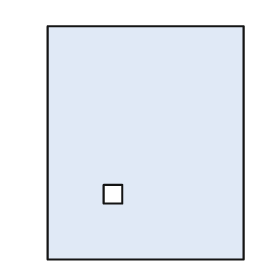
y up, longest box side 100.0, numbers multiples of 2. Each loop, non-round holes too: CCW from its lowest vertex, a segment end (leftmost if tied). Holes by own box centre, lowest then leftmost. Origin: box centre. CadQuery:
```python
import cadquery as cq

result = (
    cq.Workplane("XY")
    .moveTo(-42.0, -50.0)
    .lineTo(42.0, -50.0)
    .lineTo(42.0, 50.0)
    .lineTo(-42.0, 50.0)
    .close()
    .moveTo(-18.0, -26.0)
    .lineTo(-10.0, -26.0)
    .lineTo(-10.0, -18.0)
    .lineTo(-18.0, -18.0)
    .close()
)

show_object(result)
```